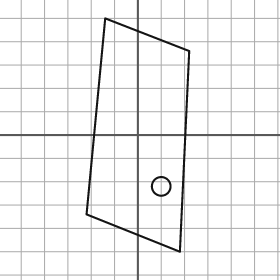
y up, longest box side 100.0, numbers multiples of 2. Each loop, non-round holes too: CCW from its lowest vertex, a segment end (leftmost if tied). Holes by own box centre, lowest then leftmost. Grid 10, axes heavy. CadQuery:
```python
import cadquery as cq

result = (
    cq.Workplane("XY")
    .moveTo(18.0, -50.0)
    .lineTo(22.0, 36.0)
    .lineTo(-14.0, 50.0)
    .lineTo(-22.0, -34.0)
    .close()
    .moveTo(10.0, -22.0)
    .circle(4.0)
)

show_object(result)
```